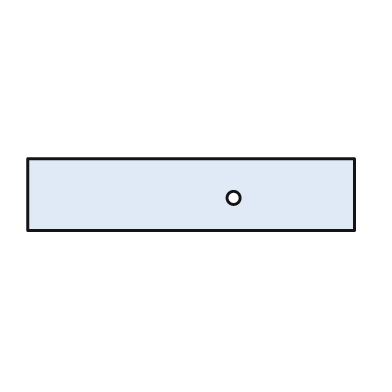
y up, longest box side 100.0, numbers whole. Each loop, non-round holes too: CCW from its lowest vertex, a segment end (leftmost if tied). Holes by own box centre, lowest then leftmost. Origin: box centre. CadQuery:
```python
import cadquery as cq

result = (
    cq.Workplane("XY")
    .moveTo(-50.0, -11.0)
    .lineTo(50.0, -11.0)
    .lineTo(50.0, 11.0)
    .lineTo(-50.0, 11.0)
    .close()
    .moveTo(13.0, -1.0)
    .circle(2.0)
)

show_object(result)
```